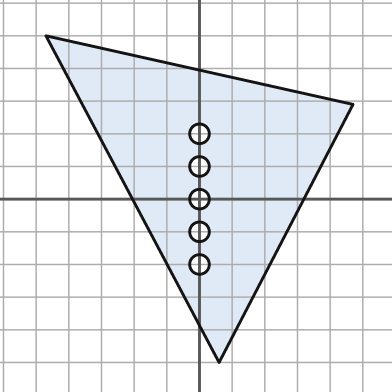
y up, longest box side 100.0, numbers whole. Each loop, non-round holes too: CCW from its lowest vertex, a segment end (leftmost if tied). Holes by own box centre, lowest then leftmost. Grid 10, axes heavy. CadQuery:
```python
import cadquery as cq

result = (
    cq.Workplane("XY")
    .moveTo(6.0, -50.0)
    .lineTo(47.0, 29.0)
    .lineTo(-47.0, 50.0)
    .close()
    .moveTo(0.0, -20.0)
    .circle(3.0)
    .moveTo(0.0, -10.0)
    .circle(3.0)
    .moveTo(0.0, 0.0)
    .circle(3.0)
    .moveTo(0.0, 10.0)
    .circle(3.0)
    .moveTo(0.0, 20.0)
    .circle(3.0)
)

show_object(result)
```